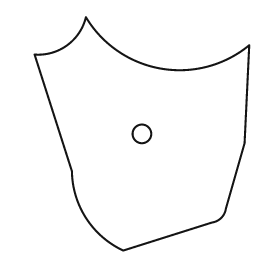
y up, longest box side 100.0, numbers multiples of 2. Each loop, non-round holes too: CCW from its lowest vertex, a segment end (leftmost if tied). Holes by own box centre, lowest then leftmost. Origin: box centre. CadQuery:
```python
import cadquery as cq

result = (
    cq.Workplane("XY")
    .moveTo(-8.0, -50.0)
    .lineTo(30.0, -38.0)
    .threePointArc((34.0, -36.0), (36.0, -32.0))
    .lineTo(44.0, -4.0)
    .lineTo(46.0, 38.0)
    .threePointArc((8.0, 28.0), (-24.0, 50.0))
    .threePointArc((-32.0, 38.0), (-46.0, 34.0))
    .lineTo(-30.0, -16.0)
    .threePointArc((-24.0, -36.0), (-8.0, -50.0))
    .close()
    .moveTo(0.0, 0.0)
    .circle(4.0)
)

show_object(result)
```